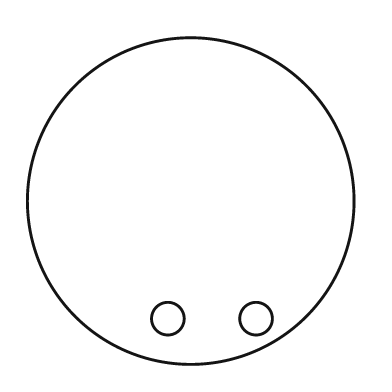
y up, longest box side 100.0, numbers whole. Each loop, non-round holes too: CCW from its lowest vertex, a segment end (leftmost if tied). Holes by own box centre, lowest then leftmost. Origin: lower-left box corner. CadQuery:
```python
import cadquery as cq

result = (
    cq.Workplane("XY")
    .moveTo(50.0, 50.0)
    .circle(50.0)
    .moveTo(43.0, 14.0)
    .circle(5.0)
    .moveTo(70.0, 14.0)
    .circle(5.0)
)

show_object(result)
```